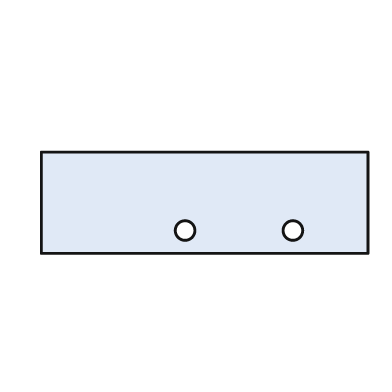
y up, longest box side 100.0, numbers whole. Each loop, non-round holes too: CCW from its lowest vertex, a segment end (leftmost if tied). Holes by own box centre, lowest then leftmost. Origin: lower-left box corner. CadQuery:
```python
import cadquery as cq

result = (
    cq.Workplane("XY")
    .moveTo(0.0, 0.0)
    .lineTo(100.0, 0.0)
    .lineTo(100.0, 31.0)
    .lineTo(0.0, 31.0)
    .close()
    .moveTo(44.0, 7.0)
    .circle(3.0)
    .moveTo(77.0, 7.0)
    .circle(3.0)
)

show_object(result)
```